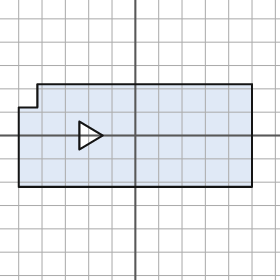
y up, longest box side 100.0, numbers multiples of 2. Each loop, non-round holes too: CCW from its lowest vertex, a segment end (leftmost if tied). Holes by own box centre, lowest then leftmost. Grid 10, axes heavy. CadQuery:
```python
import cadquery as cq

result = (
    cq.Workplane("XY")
    .moveTo(-50.0, -22.0)
    .lineTo(50.0, -22.0)
    .lineTo(50.0, 22.0)
    .lineTo(-42.0, 22.0)
    .lineTo(-42.0, 12.0)
    .lineTo(-50.0, 12.0)
    .close()
    .moveTo(-24.0, -6.0)
    .lineTo(-14.0, 0.0)
    .lineTo(-24.0, 6.0)
    .close()
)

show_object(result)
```